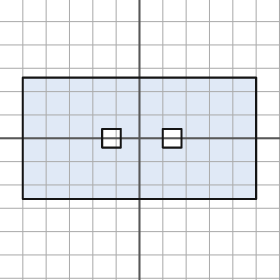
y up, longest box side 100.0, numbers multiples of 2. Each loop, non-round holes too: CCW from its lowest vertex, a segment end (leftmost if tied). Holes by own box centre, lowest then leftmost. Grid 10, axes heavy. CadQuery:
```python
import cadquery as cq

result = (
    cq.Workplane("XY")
    .moveTo(-50.0, -26.0)
    .lineTo(50.0, -26.0)
    .lineTo(50.0, 26.0)
    .lineTo(-50.0, 26.0)
    .close()
    .moveTo(-16.0, -4.0)
    .lineTo(-8.0, -4.0)
    .lineTo(-8.0, 4.0)
    .lineTo(-16.0, 4.0)
    .close()
    .moveTo(10.0, -4.0)
    .lineTo(18.0, -4.0)
    .lineTo(18.0, 4.0)
    .lineTo(10.0, 4.0)
    .close()
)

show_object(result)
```